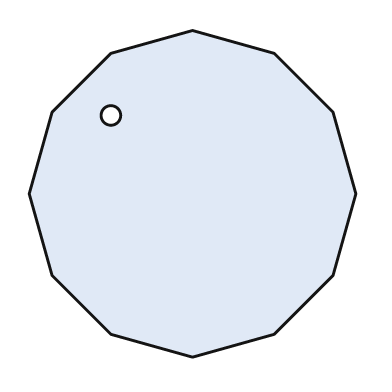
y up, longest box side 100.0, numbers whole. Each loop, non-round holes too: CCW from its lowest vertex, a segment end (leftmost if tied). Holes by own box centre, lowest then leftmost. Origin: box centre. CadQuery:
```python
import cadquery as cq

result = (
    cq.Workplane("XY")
    .moveTo(0.0, -50.0)
    .lineTo(25.0, -43.0)
    .lineTo(43.0, -25.0)
    .lineTo(50.0, 0.0)
    .lineTo(43.0, 25.0)
    .lineTo(25.0, 43.0)
    .lineTo(0.0, 50.0)
    .lineTo(-25.0, 43.0)
    .lineTo(-43.0, 25.0)
    .lineTo(-50.0, 0.0)
    .lineTo(-43.0, -25.0)
    .lineTo(-25.0, -43.0)
    .close()
    .moveTo(-25.0, 24.0)
    .circle(3.0)
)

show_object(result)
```